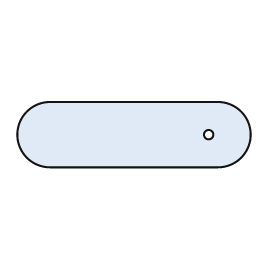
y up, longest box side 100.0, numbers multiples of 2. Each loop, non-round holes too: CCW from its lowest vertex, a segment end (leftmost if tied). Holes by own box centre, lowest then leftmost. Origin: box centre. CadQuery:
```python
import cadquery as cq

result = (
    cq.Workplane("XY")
    .moveTo(-36.0, -14.0)
    .lineTo(36.0, -14.0)
    .threePointArc((50.0, 0.0), (36.0, 14.0))
    .lineTo(-36.0, 14.0)
    .threePointArc((-50.0, 0.0), (-36.0, -14.0))
    .close()
    .moveTo(32.0, 0.0)
    .circle(2.0)
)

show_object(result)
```